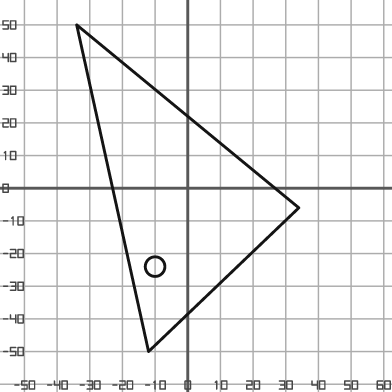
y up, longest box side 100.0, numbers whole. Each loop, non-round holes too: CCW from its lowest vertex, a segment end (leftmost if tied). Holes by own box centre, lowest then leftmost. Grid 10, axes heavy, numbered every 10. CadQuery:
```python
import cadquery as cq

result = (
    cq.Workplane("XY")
    .moveTo(-12.0, -50.0)
    .lineTo(34.0, -6.0)
    .lineTo(-34.0, 50.0)
    .close()
    .moveTo(-10.0, -24.0)
    .circle(3.0)
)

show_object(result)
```